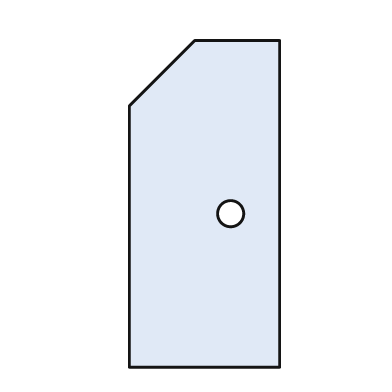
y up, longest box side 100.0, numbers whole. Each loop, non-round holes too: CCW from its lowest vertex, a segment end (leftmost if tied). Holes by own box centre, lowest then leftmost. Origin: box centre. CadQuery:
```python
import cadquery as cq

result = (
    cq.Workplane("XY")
    .moveTo(-23.0, -50.0)
    .lineTo(23.0, -50.0)
    .lineTo(23.0, 50.0)
    .lineTo(-3.0, 50.0)
    .lineTo(-23.0, 30.0)
    .close()
    .moveTo(8.0, -3.0)
    .circle(4.0)
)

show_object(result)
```